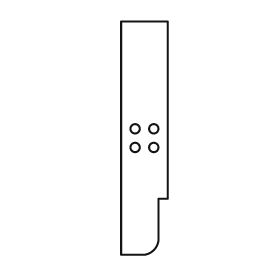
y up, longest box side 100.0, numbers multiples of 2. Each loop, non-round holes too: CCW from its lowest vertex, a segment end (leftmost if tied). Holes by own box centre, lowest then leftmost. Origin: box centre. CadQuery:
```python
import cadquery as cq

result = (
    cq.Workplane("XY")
    .moveTo(-10.0, -50.0)
    .lineTo(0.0, -50.0)
    .threePointArc((4.0, -48.0), (6.0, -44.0))
    .lineTo(6.0, -26.0)
    .lineTo(10.0, -26.0)
    .lineTo(10.0, 50.0)
    .lineTo(-10.0, 50.0)
    .close()
    .moveTo(-4.0, -4.0)
    .circle(2.0)
    .moveTo(4.0, -4.0)
    .circle(2.0)
    .moveTo(-4.0, 4.0)
    .circle(2.0)
    .moveTo(4.0, 4.0)
    .circle(2.0)
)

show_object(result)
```